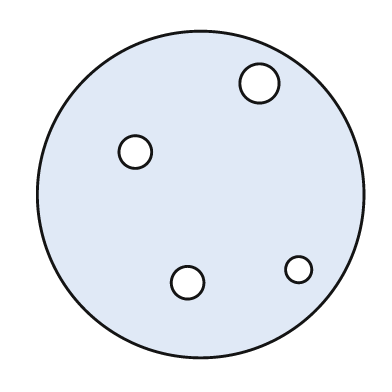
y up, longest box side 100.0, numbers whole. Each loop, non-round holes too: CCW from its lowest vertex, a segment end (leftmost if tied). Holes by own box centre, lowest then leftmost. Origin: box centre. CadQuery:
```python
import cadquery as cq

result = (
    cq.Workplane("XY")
    .moveTo(0.0, 0.0)
    .circle(50.0)
    .moveTo(-4.0, -27.0)
    .circle(5.0)
    .moveTo(30.0, -23.0)
    .circle(4.0)
    .moveTo(-20.0, 13.0)
    .circle(5.0)
    .moveTo(18.0, 34.0)
    .circle(6.0)
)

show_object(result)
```